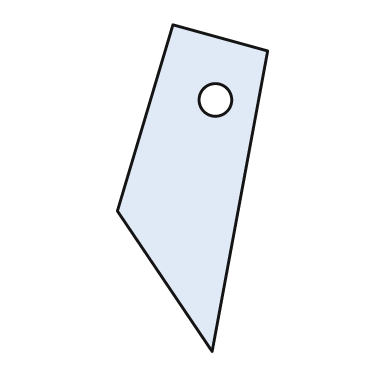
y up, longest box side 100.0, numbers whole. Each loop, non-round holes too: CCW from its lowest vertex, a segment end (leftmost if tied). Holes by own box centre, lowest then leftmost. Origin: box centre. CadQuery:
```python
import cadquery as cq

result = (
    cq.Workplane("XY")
    .moveTo(6.0, -50.0)
    .lineTo(23.0, 42.0)
    .lineTo(-6.0, 50.0)
    .lineTo(-23.0, -7.0)
    .close()
    .moveTo(7.0, 27.0)
    .circle(5.0)
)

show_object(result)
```